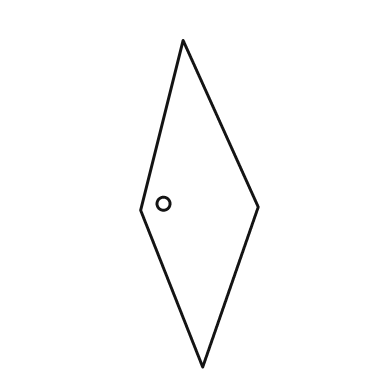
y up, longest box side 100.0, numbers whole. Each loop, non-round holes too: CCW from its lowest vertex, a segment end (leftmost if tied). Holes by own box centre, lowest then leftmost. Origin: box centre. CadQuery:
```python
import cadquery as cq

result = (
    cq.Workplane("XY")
    .moveTo(1.0, -50.0)
    .lineTo(18.0, -1.0)
    .lineTo(-5.0, 50.0)
    .lineTo(-18.0, -2.0)
    .close()
    .moveTo(-11.0, 0.0)
    .circle(2.0)
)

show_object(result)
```